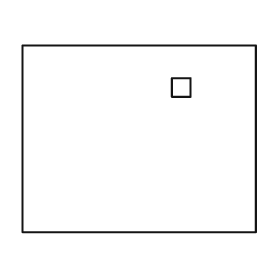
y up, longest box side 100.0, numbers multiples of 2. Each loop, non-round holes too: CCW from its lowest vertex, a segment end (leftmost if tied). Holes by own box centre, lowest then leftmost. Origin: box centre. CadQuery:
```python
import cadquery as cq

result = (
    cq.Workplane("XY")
    .moveTo(-50.0, -40.0)
    .lineTo(50.0, -40.0)
    .lineTo(50.0, 40.0)
    .lineTo(-50.0, 40.0)
    .close()
    .moveTo(14.0, 18.0)
    .lineTo(22.0, 18.0)
    .lineTo(22.0, 26.0)
    .lineTo(14.0, 26.0)
    .close()
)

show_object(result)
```